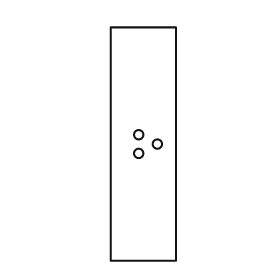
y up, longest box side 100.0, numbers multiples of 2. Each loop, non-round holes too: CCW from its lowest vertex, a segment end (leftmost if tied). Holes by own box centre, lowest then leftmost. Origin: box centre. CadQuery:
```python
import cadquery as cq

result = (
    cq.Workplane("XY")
    .moveTo(-14.0, -50.0)
    .lineTo(14.0, -50.0)
    .lineTo(14.0, 50.0)
    .lineTo(-14.0, 50.0)
    .close()
    .moveTo(-2.0, -4.0)
    .circle(2.0)
    .moveTo(6.0, 0.0)
    .circle(2.0)
    .moveTo(-2.0, 4.0)
    .circle(2.0)
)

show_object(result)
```